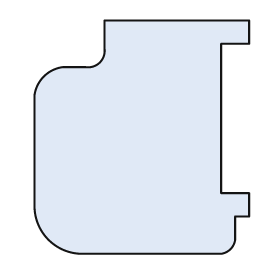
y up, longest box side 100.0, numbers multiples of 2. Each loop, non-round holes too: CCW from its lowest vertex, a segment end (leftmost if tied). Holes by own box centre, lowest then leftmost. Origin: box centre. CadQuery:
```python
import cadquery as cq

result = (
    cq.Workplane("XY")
    .moveTo(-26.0, -50.0)
    .lineTo(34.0, -50.0)
    .threePointArc((38.0, -48.0), (40.0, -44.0))
    .lineTo(40.0, -34.0)
    .lineTo(46.0, -34.0)
    .lineTo(46.0, -24.0)
    .lineTo(34.0, -24.0)
    .lineTo(34.0, 40.0)
    .lineTo(46.0, 40.0)
    .lineTo(46.0, 50.0)
    .lineTo(-16.0, 50.0)
    .lineTo(-16.0, 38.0)
    .threePointArc((-18.0, 32.0), (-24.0, 30.0))
    .lineTo(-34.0, 30.0)
    .threePointArc((-42.0, 26.0), (-46.0, 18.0))
    .lineTo(-46.0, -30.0)
    .threePointArc((-40.0, -44.0), (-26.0, -50.0))
    .close()
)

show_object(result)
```